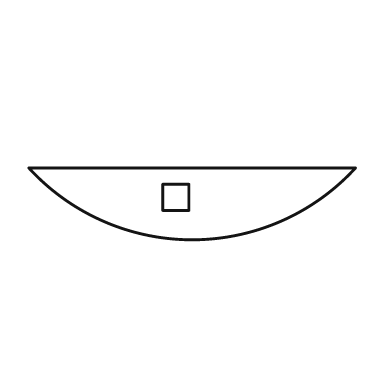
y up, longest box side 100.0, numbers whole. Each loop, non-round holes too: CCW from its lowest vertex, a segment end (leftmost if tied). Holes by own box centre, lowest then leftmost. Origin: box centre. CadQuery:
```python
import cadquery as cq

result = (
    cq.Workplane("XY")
    .moveTo(-50.0, 11.0)
    .threePointArc((0.0, -11.0), (50.0, 11.0))
    .close()
    .moveTo(-9.0, -2.0)
    .lineTo(-1.0, -2.0)
    .lineTo(-1.0, 6.0)
    .lineTo(-9.0, 6.0)
    .close()
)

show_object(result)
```